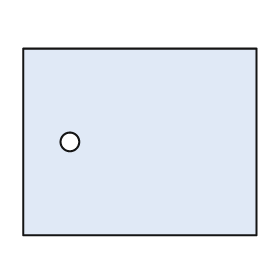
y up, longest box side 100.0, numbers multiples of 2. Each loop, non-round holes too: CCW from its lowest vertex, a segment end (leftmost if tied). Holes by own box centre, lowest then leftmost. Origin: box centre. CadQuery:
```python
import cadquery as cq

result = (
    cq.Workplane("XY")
    .moveTo(-50.0, -40.0)
    .lineTo(50.0, -40.0)
    .lineTo(50.0, 40.0)
    .lineTo(-50.0, 40.0)
    .close()
    .moveTo(-30.0, 0.0)
    .circle(4.0)
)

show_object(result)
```